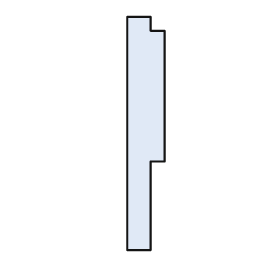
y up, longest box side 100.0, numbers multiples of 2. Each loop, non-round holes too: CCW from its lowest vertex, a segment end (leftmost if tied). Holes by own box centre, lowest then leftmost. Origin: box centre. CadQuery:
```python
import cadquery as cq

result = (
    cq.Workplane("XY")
    .moveTo(-8.0, -50.0)
    .lineTo(2.0, -50.0)
    .lineTo(2.0, -12.0)
    .lineTo(8.0, -12.0)
    .lineTo(8.0, 44.0)
    .lineTo(2.0, 44.0)
    .lineTo(2.0, 50.0)
    .lineTo(-8.0, 50.0)
    .close()
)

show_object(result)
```